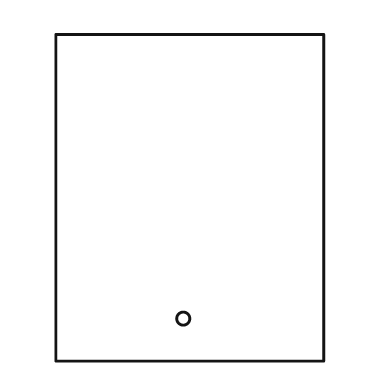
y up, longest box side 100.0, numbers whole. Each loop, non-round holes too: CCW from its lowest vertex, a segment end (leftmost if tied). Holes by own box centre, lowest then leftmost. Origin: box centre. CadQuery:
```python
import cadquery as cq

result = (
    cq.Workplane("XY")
    .moveTo(-41.0, -50.0)
    .lineTo(41.0, -50.0)
    .lineTo(41.0, 50.0)
    .lineTo(-41.0, 50.0)
    .close()
    .moveTo(-2.0, -37.0)
    .circle(2.0)
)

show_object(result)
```